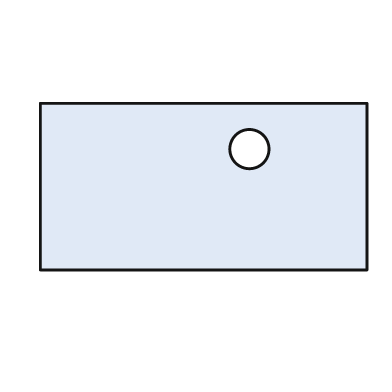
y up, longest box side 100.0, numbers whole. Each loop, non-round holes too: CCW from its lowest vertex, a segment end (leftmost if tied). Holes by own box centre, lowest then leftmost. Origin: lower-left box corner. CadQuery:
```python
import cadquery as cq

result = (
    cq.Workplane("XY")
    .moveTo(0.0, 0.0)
    .lineTo(100.0, 0.0)
    .lineTo(100.0, 51.0)
    .lineTo(0.0, 51.0)
    .close()
    .moveTo(64.0, 37.0)
    .circle(6.0)
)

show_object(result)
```